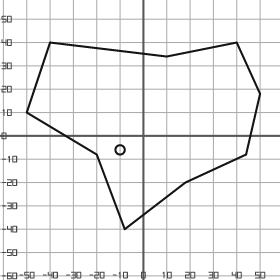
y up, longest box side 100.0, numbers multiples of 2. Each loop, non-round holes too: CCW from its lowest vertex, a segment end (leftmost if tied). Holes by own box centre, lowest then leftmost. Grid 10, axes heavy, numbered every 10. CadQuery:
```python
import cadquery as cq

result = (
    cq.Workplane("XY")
    .moveTo(-8.0, -40.0)
    .lineTo(18.0, -20.0)
    .lineTo(44.0, -8.0)
    .lineTo(50.0, 18.0)
    .lineTo(40.0, 40.0)
    .lineTo(10.0, 34.0)
    .lineTo(-40.0, 40.0)
    .lineTo(-50.0, 10.0)
    .lineTo(-20.0, -8.0)
    .close()
    .moveTo(-10.0, -6.0)
    .circle(2.0)
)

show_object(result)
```